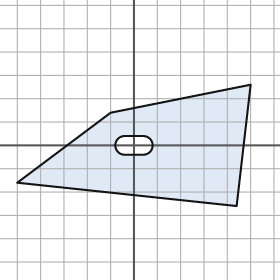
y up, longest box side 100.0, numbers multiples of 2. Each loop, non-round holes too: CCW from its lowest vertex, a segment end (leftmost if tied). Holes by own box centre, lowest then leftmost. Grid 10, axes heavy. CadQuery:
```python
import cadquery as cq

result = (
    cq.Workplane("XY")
    .moveTo(44.0, -26.0)
    .lineTo(50.0, 26.0)
    .lineTo(-10.0, 14.0)
    .lineTo(-50.0, -16.0)
    .close()
    .moveTo(-4.0, -4.0)
    .lineTo(4.0, -4.0)
    .threePointArc((8.0, 0.0), (4.0, 4.0))
    .lineTo(-4.0, 4.0)
    .threePointArc((-8.0, 0.0), (-4.0, -4.0))
    .close()
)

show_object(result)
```